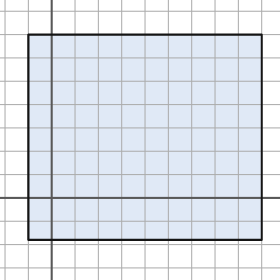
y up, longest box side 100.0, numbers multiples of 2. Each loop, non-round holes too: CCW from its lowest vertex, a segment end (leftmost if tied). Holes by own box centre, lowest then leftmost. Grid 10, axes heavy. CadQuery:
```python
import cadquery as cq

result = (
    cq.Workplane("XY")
    .moveTo(-10.0, -18.0)
    .lineTo(90.0, -18.0)
    .lineTo(90.0, 70.0)
    .lineTo(-10.0, 70.0)
    .close()
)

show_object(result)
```